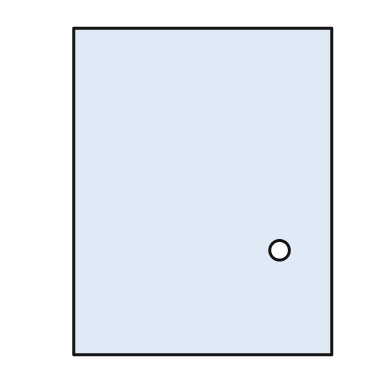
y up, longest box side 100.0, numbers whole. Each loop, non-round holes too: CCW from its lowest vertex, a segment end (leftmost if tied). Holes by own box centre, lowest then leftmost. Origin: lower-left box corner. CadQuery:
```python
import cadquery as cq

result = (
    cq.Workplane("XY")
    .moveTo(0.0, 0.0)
    .lineTo(79.0, 0.0)
    .lineTo(79.0, 100.0)
    .lineTo(0.0, 100.0)
    .close()
    .moveTo(63.0, 32.0)
    .circle(3.0)
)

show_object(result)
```